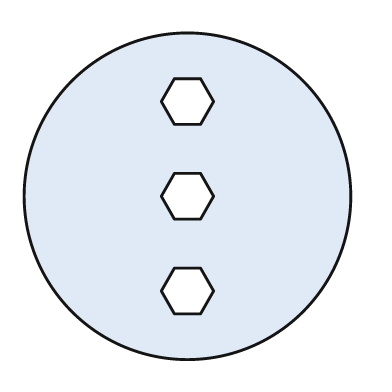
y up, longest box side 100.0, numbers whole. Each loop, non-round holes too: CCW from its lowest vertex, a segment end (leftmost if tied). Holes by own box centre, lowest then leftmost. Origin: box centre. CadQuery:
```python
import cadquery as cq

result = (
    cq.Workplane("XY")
    .moveTo(0.0, 0.0)
    .circle(50.0)
    .moveTo(-4.0, -36.0)
    .lineTo(4.0, -36.0)
    .lineTo(8.0, -29.0)
    .lineTo(4.0, -22.0)
    .lineTo(-4.0, -22.0)
    .lineTo(-8.0, -29.0)
    .close()
    .moveTo(-4.0, -7.0)
    .lineTo(4.0, -7.0)
    .lineTo(8.0, 0.0)
    .lineTo(4.0, 7.0)
    .lineTo(-4.0, 7.0)
    .lineTo(-8.0, 0.0)
    .close()
    .moveTo(-4.0, 22.0)
    .lineTo(4.0, 22.0)
    .lineTo(8.0, 29.0)
    .lineTo(4.0, 36.0)
    .lineTo(-4.0, 36.0)
    .lineTo(-8.0, 29.0)
    .close()
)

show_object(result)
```